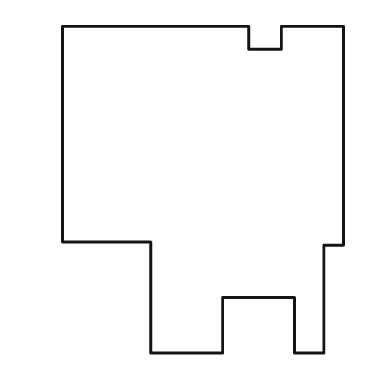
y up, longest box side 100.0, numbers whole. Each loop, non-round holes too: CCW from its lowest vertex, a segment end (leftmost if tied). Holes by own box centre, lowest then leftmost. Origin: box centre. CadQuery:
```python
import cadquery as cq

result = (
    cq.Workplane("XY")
    .moveTo(-16.0, -50.0)
    .lineTo(6.0, -50.0)
    .lineTo(6.0, -33.0)
    .lineTo(28.0, -33.0)
    .lineTo(28.0, -50.0)
    .lineTo(37.0, -50.0)
    .lineTo(37.0, -17.0)
    .lineTo(43.0, -17.0)
    .lineTo(43.0, 50.0)
    .lineTo(24.0, 50.0)
    .lineTo(24.0, 43.0)
    .lineTo(14.0, 43.0)
    .lineTo(14.0, 50.0)
    .lineTo(-43.0, 50.0)
    .lineTo(-43.0, -16.0)
    .lineTo(-16.0, -16.0)
    .close()
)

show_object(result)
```